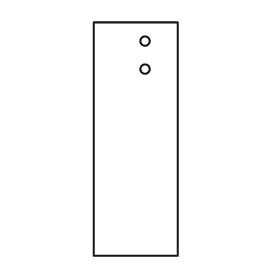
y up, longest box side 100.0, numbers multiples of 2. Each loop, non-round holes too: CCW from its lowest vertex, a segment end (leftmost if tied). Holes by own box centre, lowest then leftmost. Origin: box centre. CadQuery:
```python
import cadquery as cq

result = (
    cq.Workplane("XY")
    .moveTo(-18.0, -50.0)
    .lineTo(18.0, -50.0)
    .lineTo(18.0, 50.0)
    .lineTo(-18.0, 50.0)
    .close()
    .moveTo(4.0, 30.0)
    .circle(2.0)
    .moveTo(4.0, 42.0)
    .circle(2.0)
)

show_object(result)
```